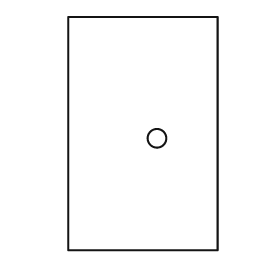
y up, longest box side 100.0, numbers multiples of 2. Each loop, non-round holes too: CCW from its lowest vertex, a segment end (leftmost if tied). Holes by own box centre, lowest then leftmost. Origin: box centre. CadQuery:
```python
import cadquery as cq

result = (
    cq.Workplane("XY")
    .moveTo(-32.0, -50.0)
    .lineTo(32.0, -50.0)
    .lineTo(32.0, 50.0)
    .lineTo(-32.0, 50.0)
    .close()
    .moveTo(6.0, -2.0)
    .circle(4.0)
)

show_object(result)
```